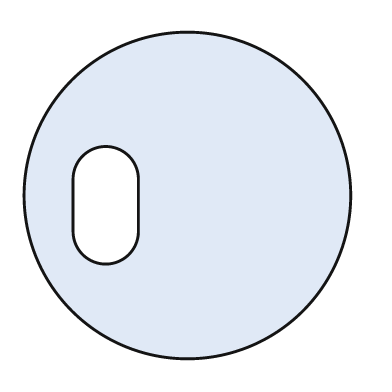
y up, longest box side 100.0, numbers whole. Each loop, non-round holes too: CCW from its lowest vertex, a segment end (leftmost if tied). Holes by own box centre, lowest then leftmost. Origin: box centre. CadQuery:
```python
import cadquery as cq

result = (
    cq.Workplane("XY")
    .moveTo(0.0, 0.0)
    .circle(50.0)
    .moveTo(-35.0, -11.0)
    .threePointArc((-25.0, -21.0), (-15.0, -11.0))
    .lineTo(-15.0, 5.0)
    .threePointArc((-25.0, 15.0), (-35.0, 5.0))
    .close()
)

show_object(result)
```